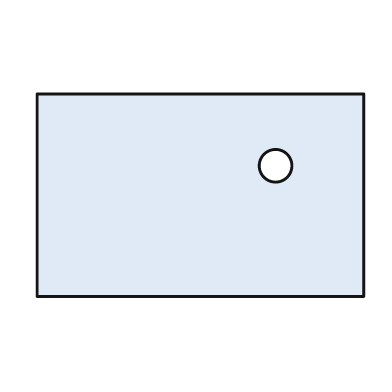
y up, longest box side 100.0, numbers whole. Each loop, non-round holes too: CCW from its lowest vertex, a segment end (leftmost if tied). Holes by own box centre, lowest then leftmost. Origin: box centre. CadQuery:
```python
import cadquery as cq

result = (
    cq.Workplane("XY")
    .moveTo(-50.0, -31.0)
    .lineTo(50.0, -31.0)
    .lineTo(50.0, 31.0)
    .lineTo(-50.0, 31.0)
    .close()
    .moveTo(23.0, 9.0)
    .circle(5.0)
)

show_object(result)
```